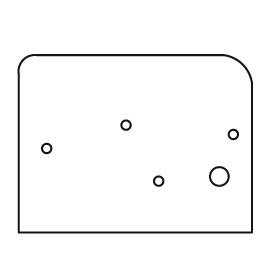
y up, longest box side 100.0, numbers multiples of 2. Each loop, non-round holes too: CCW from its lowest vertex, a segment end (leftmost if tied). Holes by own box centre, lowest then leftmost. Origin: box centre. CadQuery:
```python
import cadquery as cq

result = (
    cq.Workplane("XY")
    .moveTo(-50.0, -38.0)
    .lineTo(50.0, -38.0)
    .lineTo(50.0, 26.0)
    .threePointArc((46.0, 34.0), (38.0, 38.0))
    .lineTo(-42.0, 38.0)
    .threePointArc((-48.0, 36.0), (-50.0, 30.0))
    .close()
    .moveTo(10.0, -16.0)
    .circle(2.0)
    .moveTo(36.0, -14.0)
    .circle(4.0)
    .moveTo(-38.0, -2.0)
    .circle(2.0)
    .moveTo(42.0, 4.0)
    .circle(2.0)
    .moveTo(-4.0, 8.0)
    .circle(2.0)
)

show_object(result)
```